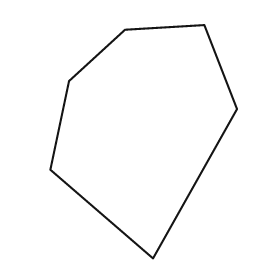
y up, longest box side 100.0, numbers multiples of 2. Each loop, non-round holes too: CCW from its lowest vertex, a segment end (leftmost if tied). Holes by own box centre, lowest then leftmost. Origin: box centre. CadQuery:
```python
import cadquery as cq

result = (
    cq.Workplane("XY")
    .moveTo(4.0, -50.0)
    .lineTo(40.0, 14.0)
    .lineTo(26.0, 50.0)
    .lineTo(-8.0, 48.0)
    .lineTo(-32.0, 26.0)
    .lineTo(-40.0, -12.0)
    .close()
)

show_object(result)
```